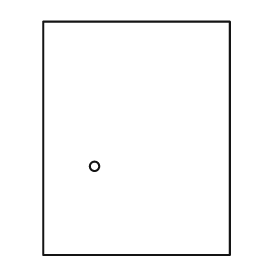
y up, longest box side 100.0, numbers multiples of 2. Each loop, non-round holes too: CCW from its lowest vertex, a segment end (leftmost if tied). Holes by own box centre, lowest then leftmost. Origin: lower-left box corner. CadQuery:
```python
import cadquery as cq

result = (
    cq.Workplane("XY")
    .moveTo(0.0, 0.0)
    .lineTo(80.0, 0.0)
    .lineTo(80.0, 100.0)
    .lineTo(0.0, 100.0)
    .close()
    .moveTo(22.0, 38.0)
    .circle(2.0)
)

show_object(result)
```